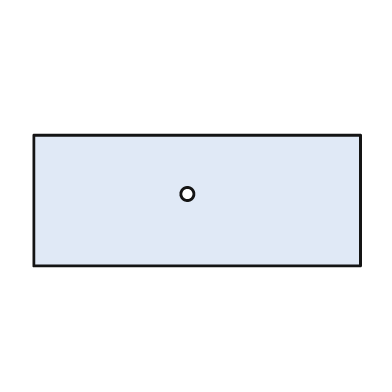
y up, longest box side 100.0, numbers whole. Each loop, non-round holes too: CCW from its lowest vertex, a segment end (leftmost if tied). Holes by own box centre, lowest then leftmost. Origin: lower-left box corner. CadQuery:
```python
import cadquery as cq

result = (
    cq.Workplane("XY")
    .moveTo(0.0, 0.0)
    .lineTo(100.0, 0.0)
    .lineTo(100.0, 40.0)
    .lineTo(0.0, 40.0)
    .close()
    .moveTo(47.0, 22.0)
    .circle(2.0)
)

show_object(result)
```